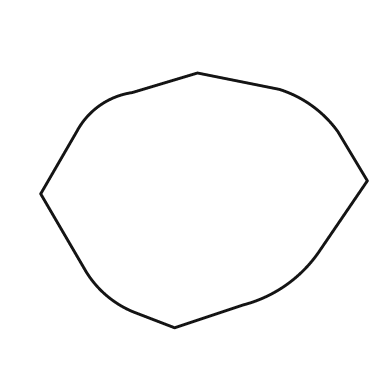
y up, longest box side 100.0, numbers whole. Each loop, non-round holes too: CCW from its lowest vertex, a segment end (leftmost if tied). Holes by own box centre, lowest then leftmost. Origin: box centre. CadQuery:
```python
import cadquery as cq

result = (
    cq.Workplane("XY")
    .moveTo(-9.0, -39.0)
    .lineTo(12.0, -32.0)
    .threePointArc((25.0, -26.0), (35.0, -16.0))
    .lineTo(50.0, 6.0)
    .lineTo(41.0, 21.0)
    .threePointArc((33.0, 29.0), (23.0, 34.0))
    .lineTo(-2.0, 39.0)
    .lineTo(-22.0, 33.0)
    .threePointArc((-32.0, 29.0), (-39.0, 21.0))
    .lineTo(-50.0, 2.0)
    .lineTo(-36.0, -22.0)
    .threePointArc((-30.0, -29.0), (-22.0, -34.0))
    .close()
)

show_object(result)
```